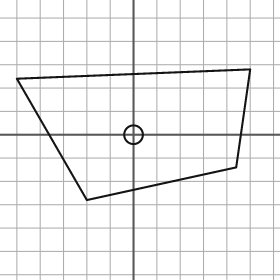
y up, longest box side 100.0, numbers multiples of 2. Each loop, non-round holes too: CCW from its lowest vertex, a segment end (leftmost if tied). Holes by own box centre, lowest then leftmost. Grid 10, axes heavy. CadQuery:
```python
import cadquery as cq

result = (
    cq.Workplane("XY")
    .moveTo(-20.0, -28.0)
    .lineTo(44.0, -14.0)
    .lineTo(50.0, 28.0)
    .lineTo(-50.0, 24.0)
    .close()
    .moveTo(0.0, 0.0)
    .circle(4.0)
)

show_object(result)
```